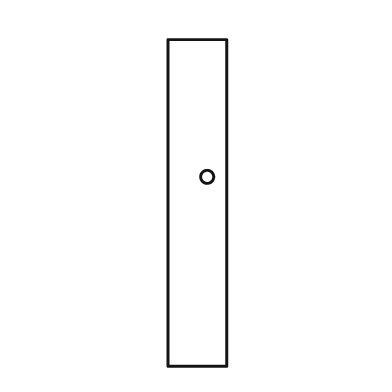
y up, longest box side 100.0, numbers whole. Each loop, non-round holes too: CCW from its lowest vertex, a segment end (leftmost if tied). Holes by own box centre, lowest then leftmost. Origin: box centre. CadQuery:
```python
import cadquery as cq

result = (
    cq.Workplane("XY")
    .moveTo(-9.0, -50.0)
    .lineTo(9.0, -50.0)
    .lineTo(9.0, 50.0)
    .lineTo(-9.0, 50.0)
    .close()
    .moveTo(3.0, 8.0)
    .circle(2.0)
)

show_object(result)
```